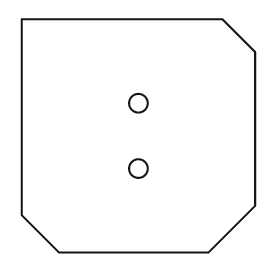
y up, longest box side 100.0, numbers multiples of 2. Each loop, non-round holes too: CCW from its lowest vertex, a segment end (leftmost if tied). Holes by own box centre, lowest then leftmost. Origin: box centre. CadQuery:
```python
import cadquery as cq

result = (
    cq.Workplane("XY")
    .moveTo(-34.0, -50.0)
    .lineTo(30.0, -50.0)
    .lineTo(50.0, -30.0)
    .lineTo(50.0, 36.0)
    .lineTo(36.0, 50.0)
    .lineTo(-50.0, 50.0)
    .lineTo(-50.0, -34.0)
    .close()
    .moveTo(0.0, -14.0)
    .circle(4.0)
    .moveTo(0.0, 14.0)
    .circle(4.0)
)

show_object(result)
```